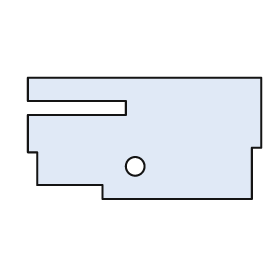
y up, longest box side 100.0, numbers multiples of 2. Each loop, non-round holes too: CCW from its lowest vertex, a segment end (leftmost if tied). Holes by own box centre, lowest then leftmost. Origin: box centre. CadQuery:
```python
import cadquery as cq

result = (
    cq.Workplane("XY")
    .moveTo(-18.0, -26.0)
    .lineTo(46.0, -26.0)
    .lineTo(46.0, -4.0)
    .lineTo(50.0, -4.0)
    .lineTo(50.0, 26.0)
    .lineTo(-50.0, 26.0)
    .lineTo(-50.0, 16.0)
    .lineTo(-8.0, 16.0)
    .lineTo(-8.0, 10.0)
    .lineTo(-50.0, 10.0)
    .lineTo(-50.0, -6.0)
    .lineTo(-46.0, -6.0)
    .lineTo(-46.0, -20.0)
    .lineTo(-18.0, -20.0)
    .close()
    .moveTo(-4.0, -12.0)
    .circle(4.0)
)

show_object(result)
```